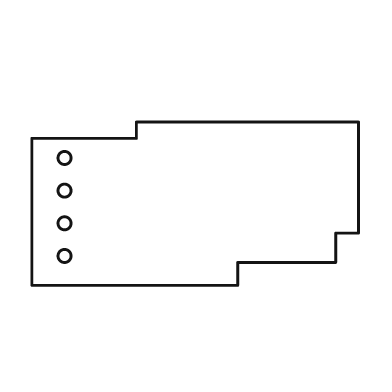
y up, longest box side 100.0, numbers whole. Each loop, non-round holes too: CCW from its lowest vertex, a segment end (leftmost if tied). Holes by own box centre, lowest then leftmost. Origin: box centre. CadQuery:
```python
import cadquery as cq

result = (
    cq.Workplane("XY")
    .moveTo(-50.0, -25.0)
    .lineTo(13.0, -25.0)
    .lineTo(13.0, -18.0)
    .lineTo(43.0, -18.0)
    .lineTo(43.0, -9.0)
    .lineTo(50.0, -9.0)
    .lineTo(50.0, 25.0)
    .lineTo(-18.0, 25.0)
    .lineTo(-18.0, 20.0)
    .lineTo(-50.0, 20.0)
    .close()
    .moveTo(-40.0, -16.0)
    .circle(2.0)
    .moveTo(-40.0, -6.0)
    .circle(2.0)
    .moveTo(-40.0, 4.0)
    .circle(2.0)
    .moveTo(-40.0, 14.0)
    .circle(2.0)
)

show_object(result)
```